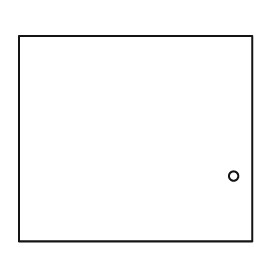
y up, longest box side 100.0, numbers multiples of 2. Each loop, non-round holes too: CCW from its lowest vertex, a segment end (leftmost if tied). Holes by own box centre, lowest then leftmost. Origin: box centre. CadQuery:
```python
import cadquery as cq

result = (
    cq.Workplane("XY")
    .moveTo(-50.0, -44.0)
    .lineTo(50.0, -44.0)
    .lineTo(50.0, 44.0)
    .lineTo(-50.0, 44.0)
    .close()
    .moveTo(42.0, -16.0)
    .circle(2.0)
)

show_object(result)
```